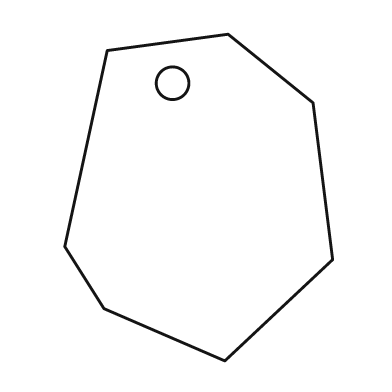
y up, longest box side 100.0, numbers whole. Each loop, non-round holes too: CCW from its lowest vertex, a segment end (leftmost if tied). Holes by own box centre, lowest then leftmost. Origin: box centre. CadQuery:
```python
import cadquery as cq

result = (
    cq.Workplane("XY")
    .moveTo(8.0, -50.0)
    .lineTo(41.0, -19.0)
    .lineTo(35.0, 29.0)
    .lineTo(9.0, 50.0)
    .lineTo(-28.0, 45.0)
    .lineTo(-41.0, -15.0)
    .lineTo(-29.0, -34.0)
    .close()
    .moveTo(-8.0, 35.0)
    .circle(5.0)
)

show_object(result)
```